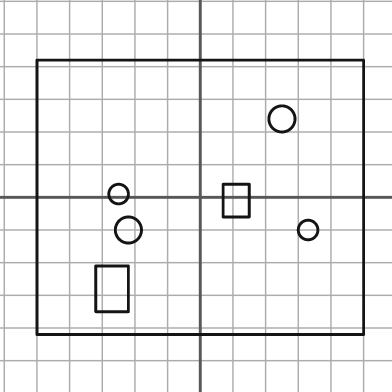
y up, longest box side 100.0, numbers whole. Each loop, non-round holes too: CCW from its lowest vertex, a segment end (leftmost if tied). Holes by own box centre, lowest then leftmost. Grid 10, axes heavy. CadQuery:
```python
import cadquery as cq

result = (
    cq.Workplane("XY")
    .moveTo(-50.0, -42.0)
    .lineTo(50.0, -42.0)
    .lineTo(50.0, 42.0)
    .lineTo(-50.0, 42.0)
    .close()
    .moveTo(-32.0, -35.0)
    .lineTo(-22.0, -35.0)
    .lineTo(-22.0, -21.0)
    .lineTo(-32.0, -21.0)
    .close()
    .moveTo(-22.0, -10.0)
    .circle(4.0)
    .moveTo(33.0, -10.0)
    .circle(3.0)
    .moveTo(7.0, -6.0)
    .lineTo(15.0, -6.0)
    .lineTo(15.0, 4.0)
    .lineTo(7.0, 4.0)
    .close()
    .moveTo(-25.0, 1.0)
    .circle(3.0)
    .moveTo(25.0, 24.0)
    .circle(4.0)
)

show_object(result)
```